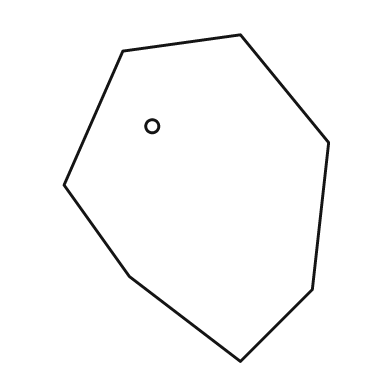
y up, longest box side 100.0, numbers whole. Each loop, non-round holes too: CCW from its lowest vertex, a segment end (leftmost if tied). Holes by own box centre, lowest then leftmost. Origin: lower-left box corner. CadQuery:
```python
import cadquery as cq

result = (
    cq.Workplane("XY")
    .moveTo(54.0, 0.0)
    .lineTo(76.0, 22.0)
    .lineTo(81.0, 67.0)
    .lineTo(54.0, 100.0)
    .lineTo(18.0, 95.0)
    .lineTo(0.0, 54.0)
    .lineTo(20.0, 26.0)
    .close()
    .moveTo(27.0, 72.0)
    .circle(2.0)
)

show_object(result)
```